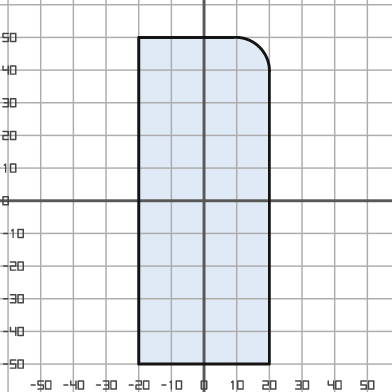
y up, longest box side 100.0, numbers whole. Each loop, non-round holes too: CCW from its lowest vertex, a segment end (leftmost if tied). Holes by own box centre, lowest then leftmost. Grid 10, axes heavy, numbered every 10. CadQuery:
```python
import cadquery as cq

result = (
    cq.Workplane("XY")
    .moveTo(-20.0, -50.0)
    .lineTo(20.0, -50.0)
    .lineTo(20.0, 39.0)
    .threePointArc((17.0, 47.0), (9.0, 50.0))
    .lineTo(-20.0, 50.0)
    .close()
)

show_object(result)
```